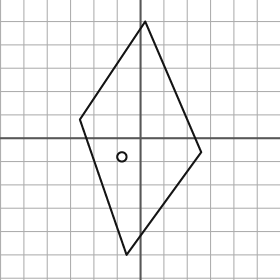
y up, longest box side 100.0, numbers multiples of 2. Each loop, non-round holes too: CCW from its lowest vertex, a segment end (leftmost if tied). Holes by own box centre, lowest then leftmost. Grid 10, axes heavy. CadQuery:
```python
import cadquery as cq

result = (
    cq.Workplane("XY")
    .moveTo(-6.0, -50.0)
    .lineTo(26.0, -6.0)
    .lineTo(2.0, 50.0)
    .lineTo(-26.0, 8.0)
    .close()
    .moveTo(-8.0, -8.0)
    .circle(2.0)
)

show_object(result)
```